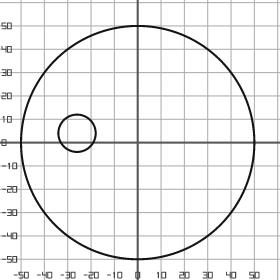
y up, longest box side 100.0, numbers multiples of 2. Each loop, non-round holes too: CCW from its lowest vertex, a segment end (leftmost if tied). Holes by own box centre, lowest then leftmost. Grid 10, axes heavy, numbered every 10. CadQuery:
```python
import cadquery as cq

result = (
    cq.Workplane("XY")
    .moveTo(0.0, 0.0)
    .circle(50.0)
    .moveTo(-26.0, 4.0)
    .circle(8.0)
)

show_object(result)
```